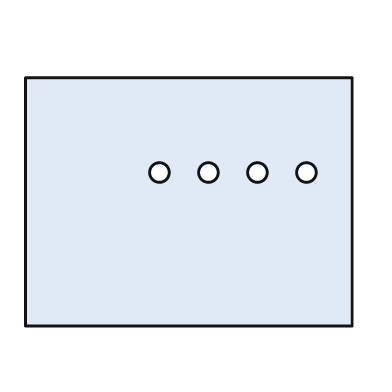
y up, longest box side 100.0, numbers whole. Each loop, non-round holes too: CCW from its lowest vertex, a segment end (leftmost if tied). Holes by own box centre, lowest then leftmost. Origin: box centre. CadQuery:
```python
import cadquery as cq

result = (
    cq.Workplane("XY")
    .moveTo(-50.0, -38.0)
    .lineTo(50.0, -38.0)
    .lineTo(50.0, 38.0)
    .lineTo(-50.0, 38.0)
    .close()
    .moveTo(-9.0, 9.0)
    .circle(3.0)
    .moveTo(6.0, 9.0)
    .circle(3.0)
    .moveTo(21.0, 9.0)
    .circle(3.0)
    .moveTo(36.0, 9.0)
    .circle(3.0)
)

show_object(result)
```